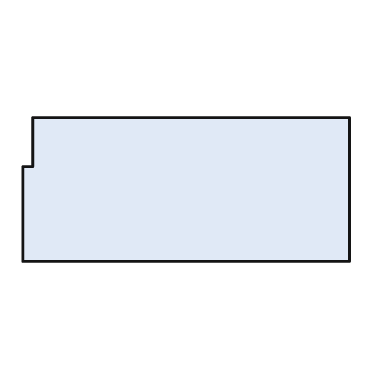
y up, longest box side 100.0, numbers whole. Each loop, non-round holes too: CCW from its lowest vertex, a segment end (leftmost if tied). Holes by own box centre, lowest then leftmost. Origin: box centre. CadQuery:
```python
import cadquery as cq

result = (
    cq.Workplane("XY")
    .moveTo(-50.0, -22.0)
    .lineTo(50.0, -22.0)
    .lineTo(50.0, 22.0)
    .lineTo(-47.0, 22.0)
    .lineTo(-47.0, 7.0)
    .lineTo(-50.0, 7.0)
    .close()
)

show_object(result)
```